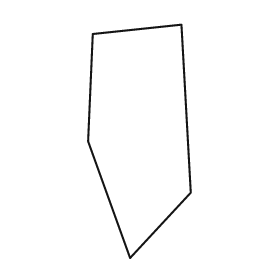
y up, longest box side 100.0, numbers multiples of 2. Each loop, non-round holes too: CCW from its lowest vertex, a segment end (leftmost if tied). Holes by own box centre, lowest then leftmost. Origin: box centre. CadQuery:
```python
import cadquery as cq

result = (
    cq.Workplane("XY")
    .moveTo(-4.0, -50.0)
    .lineTo(22.0, -22.0)
    .lineTo(18.0, 50.0)
    .lineTo(-20.0, 46.0)
    .lineTo(-22.0, 0.0)
    .close()
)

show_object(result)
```